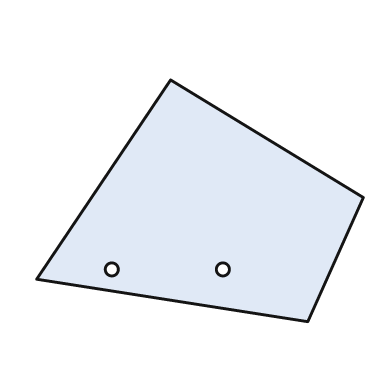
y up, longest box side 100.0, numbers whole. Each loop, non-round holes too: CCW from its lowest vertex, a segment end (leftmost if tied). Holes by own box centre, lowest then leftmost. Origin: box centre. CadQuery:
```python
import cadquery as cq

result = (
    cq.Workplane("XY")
    .moveTo(33.0, -37.0)
    .lineTo(50.0, 1.0)
    .lineTo(-9.0, 37.0)
    .lineTo(-50.0, -24.0)
    .close()
    .moveTo(-27.0, -21.0)
    .circle(2.0)
    .moveTo(7.0, -21.0)
    .circle(2.0)
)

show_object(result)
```